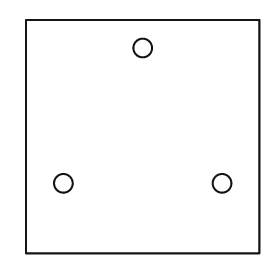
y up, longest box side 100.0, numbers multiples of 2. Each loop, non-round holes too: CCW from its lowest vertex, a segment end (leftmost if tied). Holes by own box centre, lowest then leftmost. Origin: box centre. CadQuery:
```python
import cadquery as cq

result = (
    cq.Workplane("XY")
    .moveTo(-50.0, -50.0)
    .lineTo(50.0, -50.0)
    .lineTo(50.0, 50.0)
    .lineTo(-50.0, 50.0)
    .close()
    .moveTo(-34.0, -20.0)
    .circle(4.0)
    .moveTo(34.0, -20.0)
    .circle(4.0)
    .moveTo(0.0, 38.0)
    .circle(4.0)
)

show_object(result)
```